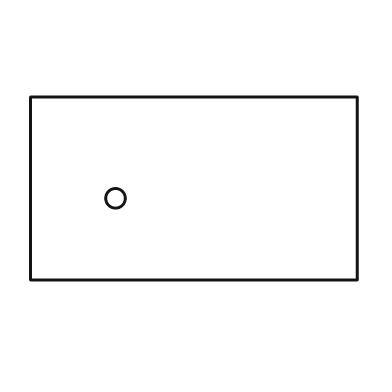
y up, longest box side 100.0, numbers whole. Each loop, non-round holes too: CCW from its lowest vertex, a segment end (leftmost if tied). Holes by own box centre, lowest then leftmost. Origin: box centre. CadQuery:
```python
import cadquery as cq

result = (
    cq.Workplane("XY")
    .moveTo(-50.0, -28.0)
    .lineTo(50.0, -28.0)
    .lineTo(50.0, 28.0)
    .lineTo(-50.0, 28.0)
    .close()
    .moveTo(-24.0, -3.0)
    .circle(3.0)
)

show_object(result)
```